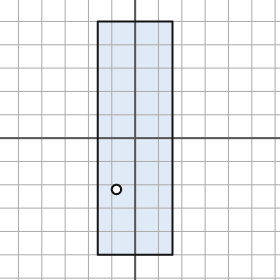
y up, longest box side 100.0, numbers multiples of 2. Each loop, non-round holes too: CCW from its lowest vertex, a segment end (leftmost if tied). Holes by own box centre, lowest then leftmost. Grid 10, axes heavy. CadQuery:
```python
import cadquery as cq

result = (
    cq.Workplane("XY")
    .moveTo(-16.0, -50.0)
    .lineTo(16.0, -50.0)
    .lineTo(16.0, 50.0)
    .lineTo(-16.0, 50.0)
    .close()
    .moveTo(-8.0, -22.0)
    .circle(2.0)
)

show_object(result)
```